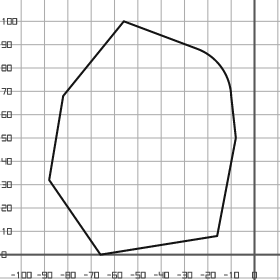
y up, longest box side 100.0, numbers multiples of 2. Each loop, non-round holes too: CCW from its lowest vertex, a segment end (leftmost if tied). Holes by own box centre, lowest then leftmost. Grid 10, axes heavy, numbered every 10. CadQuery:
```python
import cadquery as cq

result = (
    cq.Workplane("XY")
    .moveTo(-66.0, 0.0)
    .lineTo(-16.0, 8.0)
    .lineTo(-8.0, 50.0)
    .lineTo(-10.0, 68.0)
    .threePointArc((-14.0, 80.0), (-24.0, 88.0))
    .lineTo(-56.0, 100.0)
    .lineTo(-82.0, 68.0)
    .lineTo(-88.0, 32.0)
    .close()
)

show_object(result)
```